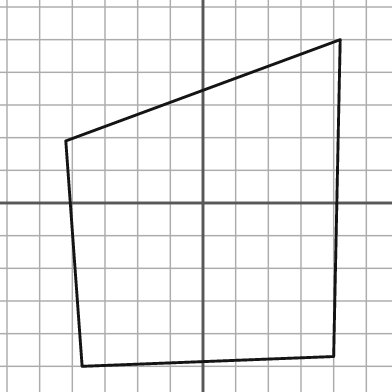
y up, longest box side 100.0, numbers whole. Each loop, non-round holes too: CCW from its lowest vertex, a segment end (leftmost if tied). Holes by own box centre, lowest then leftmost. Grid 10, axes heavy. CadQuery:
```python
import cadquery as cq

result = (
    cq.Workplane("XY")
    .moveTo(-37.0, -50.0)
    .lineTo(40.0, -47.0)
    .lineTo(42.0, 50.0)
    .lineTo(-42.0, 19.0)
    .close()
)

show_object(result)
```